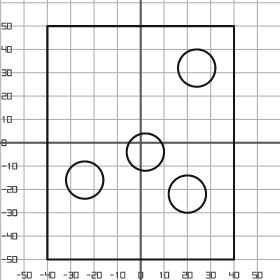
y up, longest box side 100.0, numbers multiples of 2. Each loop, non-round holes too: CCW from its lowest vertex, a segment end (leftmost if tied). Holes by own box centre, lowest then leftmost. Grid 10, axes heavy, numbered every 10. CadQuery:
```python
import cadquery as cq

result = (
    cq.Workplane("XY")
    .moveTo(-40.0, -50.0)
    .lineTo(40.0, -50.0)
    .lineTo(40.0, 50.0)
    .lineTo(-40.0, 50.0)
    .close()
    .moveTo(20.0, -22.0)
    .circle(8.0)
    .moveTo(-24.0, -16.0)
    .circle(8.0)
    .moveTo(2.0, -4.0)
    .circle(8.0)
    .moveTo(24.0, 32.0)
    .circle(8.0)
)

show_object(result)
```